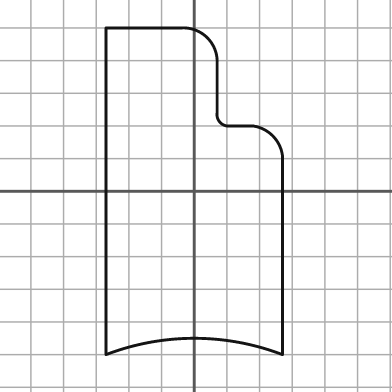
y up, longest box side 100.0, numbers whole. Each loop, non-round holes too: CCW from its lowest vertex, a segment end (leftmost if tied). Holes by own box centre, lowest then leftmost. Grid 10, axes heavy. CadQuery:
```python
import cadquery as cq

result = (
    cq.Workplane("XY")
    .moveTo(-27.0, -50.0)
    .threePointArc((0.0, -45.0), (27.0, -50.0))
    .lineTo(27.0, 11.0)
    .threePointArc((24.0, 17.0), (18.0, 20.0))
    .lineTo(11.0, 20.0)
    .threePointArc((8.0, 21.0), (7.0, 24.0))
    .lineTo(7.0, 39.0)
    .threePointArc((4.0, 47.0), (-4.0, 50.0))
    .lineTo(-27.0, 50.0)
    .close()
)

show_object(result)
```